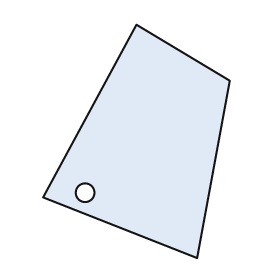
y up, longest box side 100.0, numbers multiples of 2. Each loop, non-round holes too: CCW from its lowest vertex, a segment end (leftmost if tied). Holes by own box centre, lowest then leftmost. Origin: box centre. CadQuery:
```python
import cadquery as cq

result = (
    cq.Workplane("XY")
    .moveTo(26.0, -50.0)
    .lineTo(40.0, 26.0)
    .lineTo(0.0, 50.0)
    .lineTo(-40.0, -24.0)
    .close()
    .moveTo(-22.0, -22.0)
    .circle(4.0)
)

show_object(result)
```